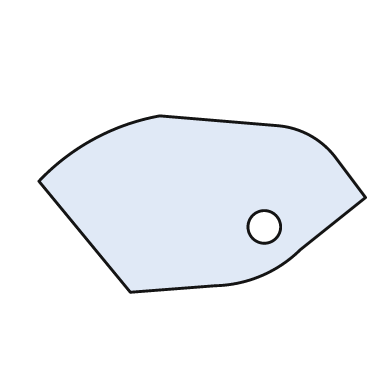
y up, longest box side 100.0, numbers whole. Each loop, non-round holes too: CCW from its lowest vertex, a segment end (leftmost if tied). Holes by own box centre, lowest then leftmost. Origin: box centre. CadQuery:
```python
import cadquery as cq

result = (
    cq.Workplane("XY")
    .moveTo(-22.0, -27.0)
    .lineTo(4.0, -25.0)
    .threePointArc((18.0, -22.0), (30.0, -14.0))
    .lineTo(50.0, 2.0)
    .lineTo(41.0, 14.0)
    .threePointArc((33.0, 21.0), (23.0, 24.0))
    .lineTo(-13.0, 27.0)
    .threePointArc((-33.0, 20.0), (-50.0, 7.0))
    .close()
    .moveTo(19.0, -7.0)
    .circle(5.0)
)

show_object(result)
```